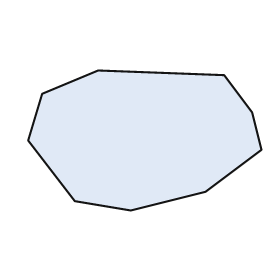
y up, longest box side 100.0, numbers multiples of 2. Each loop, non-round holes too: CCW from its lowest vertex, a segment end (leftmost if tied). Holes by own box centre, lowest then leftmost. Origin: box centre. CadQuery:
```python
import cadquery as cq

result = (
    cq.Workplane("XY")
    .moveTo(-6.0, -30.0)
    .lineTo(26.0, -22.0)
    .lineTo(50.0, -4.0)
    .lineTo(46.0, 12.0)
    .lineTo(34.0, 28.0)
    .lineTo(-20.0, 30.0)
    .lineTo(-44.0, 20.0)
    .lineTo(-50.0, 0.0)
    .lineTo(-30.0, -26.0)
    .close()
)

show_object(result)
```